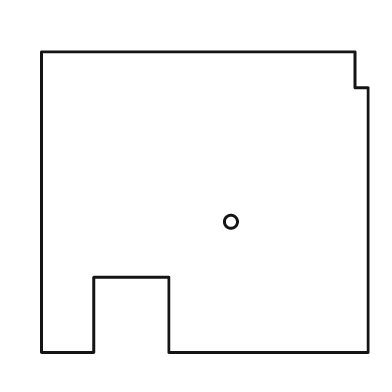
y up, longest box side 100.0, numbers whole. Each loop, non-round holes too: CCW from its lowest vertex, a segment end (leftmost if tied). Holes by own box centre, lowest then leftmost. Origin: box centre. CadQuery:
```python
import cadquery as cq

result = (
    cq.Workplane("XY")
    .moveTo(-50.0, -46.0)
    .lineTo(-34.0, -46.0)
    .lineTo(-34.0, -23.0)
    .lineTo(-11.0, -23.0)
    .lineTo(-11.0, -46.0)
    .lineTo(50.0, -46.0)
    .lineTo(50.0, 35.0)
    .lineTo(46.0, 35.0)
    .lineTo(46.0, 46.0)
    .lineTo(-50.0, 46.0)
    .close()
    .moveTo(8.0, -6.0)
    .circle(2.0)
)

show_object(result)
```